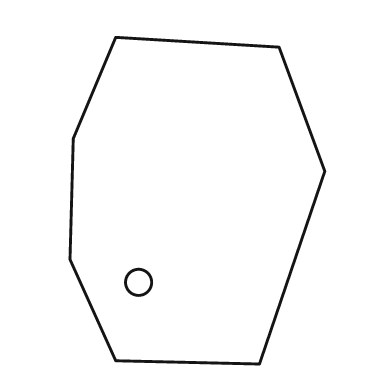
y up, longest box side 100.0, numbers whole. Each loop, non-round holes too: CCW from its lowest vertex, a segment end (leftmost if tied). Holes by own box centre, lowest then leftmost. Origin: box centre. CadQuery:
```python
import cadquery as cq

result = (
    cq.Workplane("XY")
    .moveTo(19.0, -50.0)
    .lineTo(39.0, 9.0)
    .lineTo(25.0, 47.0)
    .lineTo(-25.0, 50.0)
    .lineTo(-38.0, 19.0)
    .lineTo(-39.0, -18.0)
    .lineTo(-25.0, -49.0)
    .close()
    .moveTo(-18.0, -25.0)
    .circle(4.0)
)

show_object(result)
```